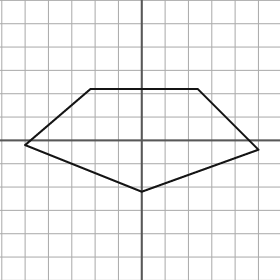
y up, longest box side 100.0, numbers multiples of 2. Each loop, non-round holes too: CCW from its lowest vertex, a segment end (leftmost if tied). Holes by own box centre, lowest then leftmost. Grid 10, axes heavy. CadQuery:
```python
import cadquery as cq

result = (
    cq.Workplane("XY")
    .moveTo(0.0, -22.0)
    .lineTo(50.0, -4.0)
    .lineTo(24.0, 22.0)
    .lineTo(-22.0, 22.0)
    .lineTo(-50.0, -2.0)
    .close()
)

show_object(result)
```